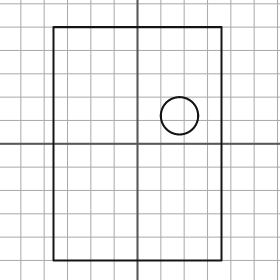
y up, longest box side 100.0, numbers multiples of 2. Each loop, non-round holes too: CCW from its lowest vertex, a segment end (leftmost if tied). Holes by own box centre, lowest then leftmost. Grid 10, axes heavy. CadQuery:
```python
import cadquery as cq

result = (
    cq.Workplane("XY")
    .moveTo(-36.0, -50.0)
    .lineTo(36.0, -50.0)
    .lineTo(36.0, 50.0)
    .lineTo(-36.0, 50.0)
    .close()
    .moveTo(18.0, 12.0)
    .circle(8.0)
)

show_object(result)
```